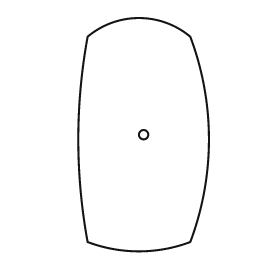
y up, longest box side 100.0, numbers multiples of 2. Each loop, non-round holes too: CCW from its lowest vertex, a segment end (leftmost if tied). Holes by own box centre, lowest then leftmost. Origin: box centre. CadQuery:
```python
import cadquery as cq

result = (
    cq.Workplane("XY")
    .moveTo(-24.0, -46.0)
    .threePointArc((-2.0, -50.0), (20.0, -46.0))
    .threePointArc((28.0, -2.0), (20.0, 42.0))
    .threePointArc((-2.0, 50.0), (-24.0, 42.0))
    .threePointArc((-28.0, -2.0), (-24.0, -46.0))
    .close()
    .moveTo(0.0, 0.0)
    .circle(2.0)
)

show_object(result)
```